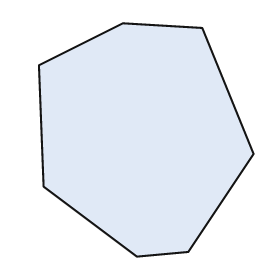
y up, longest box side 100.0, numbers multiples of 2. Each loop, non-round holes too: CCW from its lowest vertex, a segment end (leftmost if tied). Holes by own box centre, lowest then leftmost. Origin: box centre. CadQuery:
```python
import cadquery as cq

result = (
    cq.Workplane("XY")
    .moveTo(-4.0, -50.0)
    .lineTo(18.0, -48.0)
    .lineTo(46.0, -6.0)
    .lineTo(24.0, 48.0)
    .lineTo(-10.0, 50.0)
    .lineTo(-46.0, 32.0)
    .lineTo(-44.0, -20.0)
    .close()
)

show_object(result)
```